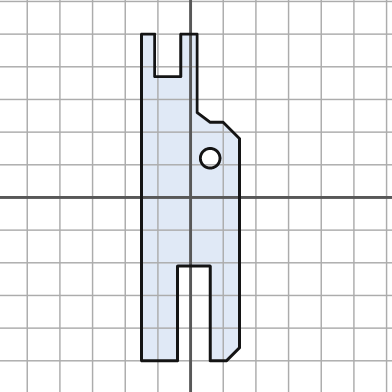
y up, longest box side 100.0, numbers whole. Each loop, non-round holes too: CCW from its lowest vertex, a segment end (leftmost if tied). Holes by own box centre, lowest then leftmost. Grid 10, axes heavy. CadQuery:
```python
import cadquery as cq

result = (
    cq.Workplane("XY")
    .moveTo(-15.0, -50.0)
    .lineTo(-4.0, -50.0)
    .lineTo(-4.0, -21.0)
    .lineTo(6.0, -21.0)
    .lineTo(6.0, -50.0)
    .lineTo(11.0, -50.0)
    .lineTo(15.0, -46.0)
    .lineTo(15.0, 18.0)
    .lineTo(10.0, 23.0)
    .lineTo(6.0, 23.0)
    .lineTo(2.0, 26.0)
    .lineTo(2.0, 50.0)
    .lineTo(-3.0, 50.0)
    .lineTo(-3.0, 37.0)
    .lineTo(-11.0, 37.0)
    .lineTo(-11.0, 50.0)
    .lineTo(-15.0, 50.0)
    .close()
    .moveTo(6.0, 12.0)
    .circle(3.0)
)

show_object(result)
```